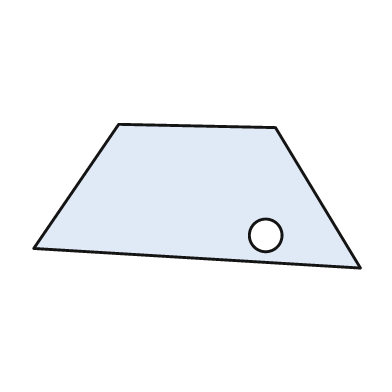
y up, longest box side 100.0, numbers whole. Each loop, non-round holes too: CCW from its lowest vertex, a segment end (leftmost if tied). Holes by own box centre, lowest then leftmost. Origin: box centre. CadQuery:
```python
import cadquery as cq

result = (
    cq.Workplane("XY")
    .moveTo(50.0, -22.0)
    .lineTo(24.0, 21.0)
    .lineTo(-24.0, 22.0)
    .lineTo(-50.0, -16.0)
    .close()
    .moveTo(21.0, -12.0)
    .circle(5.0)
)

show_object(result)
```